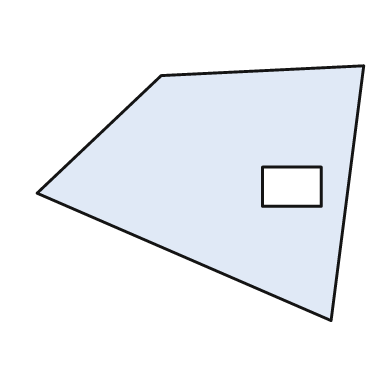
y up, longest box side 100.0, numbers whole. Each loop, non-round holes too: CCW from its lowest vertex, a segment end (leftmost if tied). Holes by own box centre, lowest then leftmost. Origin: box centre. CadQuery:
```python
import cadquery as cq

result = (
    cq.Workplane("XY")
    .moveTo(40.0, -39.0)
    .lineTo(50.0, 39.0)
    .lineTo(-12.0, 36.0)
    .lineTo(-50.0, 0.0)
    .close()
    .moveTo(19.0, -4.0)
    .lineTo(37.0, -4.0)
    .lineTo(37.0, 8.0)
    .lineTo(19.0, 8.0)
    .close()
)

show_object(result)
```